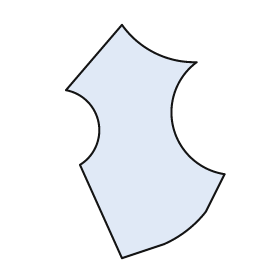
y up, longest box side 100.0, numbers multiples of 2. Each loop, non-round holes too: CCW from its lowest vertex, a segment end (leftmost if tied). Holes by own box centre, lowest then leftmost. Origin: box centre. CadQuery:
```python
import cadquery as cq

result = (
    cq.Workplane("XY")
    .moveTo(-10.0, -50.0)
    .lineTo(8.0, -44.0)
    .threePointArc((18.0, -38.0), (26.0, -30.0))
    .lineTo(34.0, -14.0)
    .threePointArc((12.0, 6.0), (22.0, 34.0))
    .threePointArc((4.0, 38.0), (-10.0, 50.0))
    .lineTo(-34.0, 22.0)
    .threePointArc((-20.0, 8.0), (-28.0, -10.0))
    .close()
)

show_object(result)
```